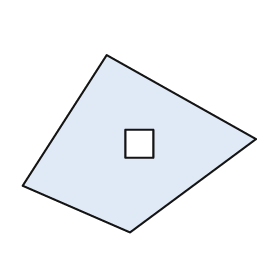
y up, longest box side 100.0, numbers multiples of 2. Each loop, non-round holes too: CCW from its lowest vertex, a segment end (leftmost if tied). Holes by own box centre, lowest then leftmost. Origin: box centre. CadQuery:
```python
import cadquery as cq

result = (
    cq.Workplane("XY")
    .moveTo(-4.0, -38.0)
    .lineTo(50.0, 2.0)
    .lineTo(-14.0, 38.0)
    .lineTo(-50.0, -18.0)
    .close()
    .moveTo(-6.0, -6.0)
    .lineTo(6.0, -6.0)
    .lineTo(6.0, 6.0)
    .lineTo(-6.0, 6.0)
    .close()
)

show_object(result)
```